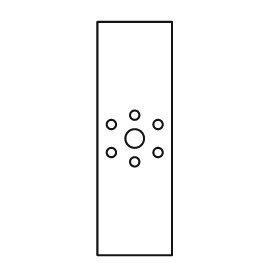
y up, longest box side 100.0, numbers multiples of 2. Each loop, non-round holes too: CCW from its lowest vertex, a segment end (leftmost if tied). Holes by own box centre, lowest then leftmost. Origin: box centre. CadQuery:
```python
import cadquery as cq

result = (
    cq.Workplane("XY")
    .moveTo(-16.0, -50.0)
    .lineTo(16.0, -50.0)
    .lineTo(16.0, 50.0)
    .lineTo(-16.0, 50.0)
    .close()
    .moveTo(0.0, -10.0)
    .circle(2.0)
    .moveTo(-10.0, -6.0)
    .circle(2.0)
    .moveTo(10.0, -6.0)
    .circle(2.0)
    .moveTo(0.0, 0.0)
    .circle(4.0)
    .moveTo(-10.0, 6.0)
    .circle(2.0)
    .moveTo(10.0, 6.0)
    .circle(2.0)
    .moveTo(0.0, 10.0)
    .circle(2.0)
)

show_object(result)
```